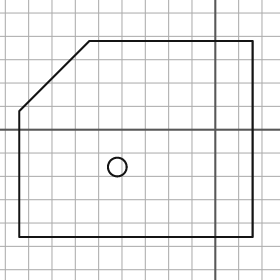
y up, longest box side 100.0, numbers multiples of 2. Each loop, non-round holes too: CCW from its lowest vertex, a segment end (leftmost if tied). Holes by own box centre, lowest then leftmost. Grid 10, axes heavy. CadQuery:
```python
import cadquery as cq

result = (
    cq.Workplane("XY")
    .moveTo(-84.0, -46.0)
    .lineTo(16.0, -46.0)
    .lineTo(16.0, 38.0)
    .lineTo(-54.0, 38.0)
    .lineTo(-84.0, 8.0)
    .close()
    .moveTo(-42.0, -16.0)
    .circle(4.0)
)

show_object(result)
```